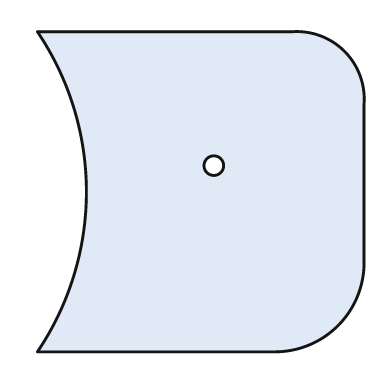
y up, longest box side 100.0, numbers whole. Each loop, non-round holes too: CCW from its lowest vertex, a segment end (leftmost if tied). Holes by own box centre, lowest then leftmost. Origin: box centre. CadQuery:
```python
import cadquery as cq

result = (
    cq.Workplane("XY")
    .moveTo(-50.0, -49.0)
    .lineTo(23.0, -49.0)
    .threePointArc((42.0, -41.0), (50.0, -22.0))
    .lineTo(50.0, 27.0)
    .threePointArc((44.0, 43.0), (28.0, 49.0))
    .lineTo(-50.0, 49.0)
    .threePointArc((-35.0, 0.0), (-50.0, -49.0))
    .close()
    .moveTo(4.0, 8.0)
    .circle(3.0)
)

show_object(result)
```